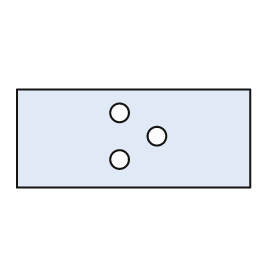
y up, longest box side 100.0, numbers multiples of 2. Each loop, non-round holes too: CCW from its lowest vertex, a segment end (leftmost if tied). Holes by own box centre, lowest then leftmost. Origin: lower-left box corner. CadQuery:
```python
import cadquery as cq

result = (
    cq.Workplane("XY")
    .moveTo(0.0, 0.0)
    .lineTo(100.0, 0.0)
    .lineTo(100.0, 42.0)
    .lineTo(0.0, 42.0)
    .close()
    .moveTo(44.0, 12.0)
    .circle(4.0)
    .moveTo(60.0, 22.0)
    .circle(4.0)
    .moveTo(44.0, 32.0)
    .circle(4.0)
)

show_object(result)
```